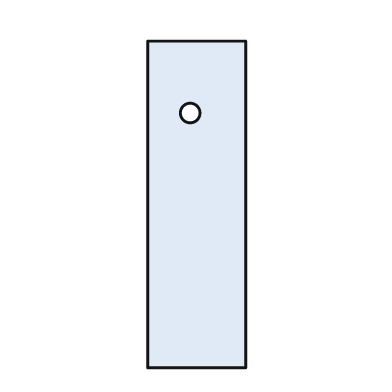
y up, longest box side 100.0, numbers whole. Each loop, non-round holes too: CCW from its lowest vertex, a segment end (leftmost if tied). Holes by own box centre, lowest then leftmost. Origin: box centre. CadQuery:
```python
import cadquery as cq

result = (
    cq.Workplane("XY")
    .moveTo(-15.0, -50.0)
    .lineTo(15.0, -50.0)
    .lineTo(15.0, 50.0)
    .lineTo(-15.0, 50.0)
    .close()
    .moveTo(-2.0, 28.0)
    .circle(3.0)
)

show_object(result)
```